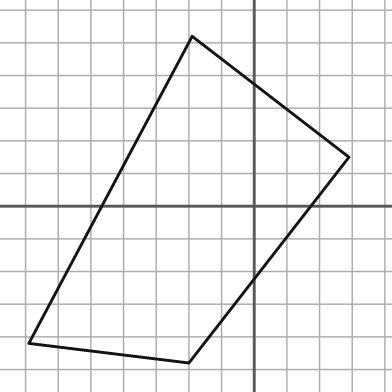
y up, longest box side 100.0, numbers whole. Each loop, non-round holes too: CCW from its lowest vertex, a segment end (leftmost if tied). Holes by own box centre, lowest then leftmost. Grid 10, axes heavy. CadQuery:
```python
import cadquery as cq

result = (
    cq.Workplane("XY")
    .moveTo(-20.0, -48.0)
    .lineTo(29.0, 15.0)
    .lineTo(-19.0, 52.0)
    .lineTo(-69.0, -42.0)
    .close()
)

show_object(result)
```